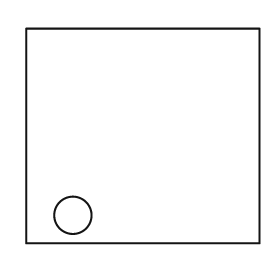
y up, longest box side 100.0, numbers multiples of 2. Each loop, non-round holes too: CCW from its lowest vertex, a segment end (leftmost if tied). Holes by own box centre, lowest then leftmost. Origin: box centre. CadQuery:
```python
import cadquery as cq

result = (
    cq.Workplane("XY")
    .moveTo(-50.0, -46.0)
    .lineTo(50.0, -46.0)
    .lineTo(50.0, 46.0)
    .lineTo(-50.0, 46.0)
    .close()
    .moveTo(-30.0, -34.0)
    .circle(8.0)
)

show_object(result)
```